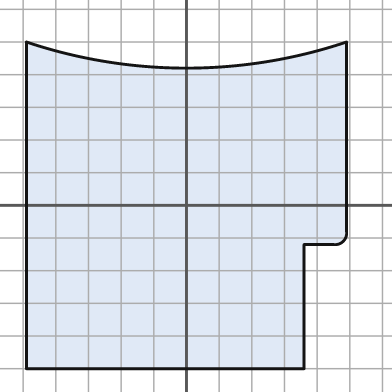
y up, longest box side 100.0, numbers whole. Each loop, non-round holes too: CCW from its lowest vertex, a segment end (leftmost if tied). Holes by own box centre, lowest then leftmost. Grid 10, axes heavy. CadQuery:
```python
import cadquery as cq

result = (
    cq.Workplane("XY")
    .moveTo(-49.0, -50.0)
    .lineTo(36.0, -50.0)
    .lineTo(36.0, -12.0)
    .lineTo(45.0, -12.0)
    .threePointArc((48.0, -11.0), (49.0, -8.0))
    .lineTo(49.0, 50.0)
    .threePointArc((0.0, 42.0), (-49.0, 50.0))
    .close()
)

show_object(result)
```